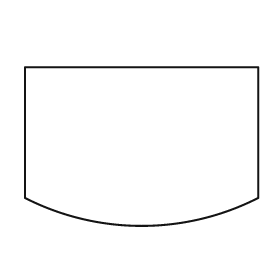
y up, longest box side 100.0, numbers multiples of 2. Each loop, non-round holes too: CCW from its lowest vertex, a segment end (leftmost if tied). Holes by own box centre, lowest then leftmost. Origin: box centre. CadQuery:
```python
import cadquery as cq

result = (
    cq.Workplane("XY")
    .moveTo(-50.0, -22.0)
    .threePointArc((0.0, -34.0), (50.0, -22.0))
    .lineTo(50.0, 34.0)
    .lineTo(-50.0, 34.0)
    .close()
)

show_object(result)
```